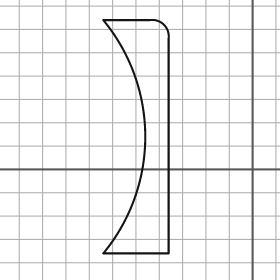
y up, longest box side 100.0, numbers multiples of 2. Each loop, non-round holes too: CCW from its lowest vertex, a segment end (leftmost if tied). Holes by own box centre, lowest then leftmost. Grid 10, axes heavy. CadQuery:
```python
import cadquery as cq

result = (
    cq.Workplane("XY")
    .moveTo(-64.0, -36.0)
    .lineTo(-36.0, -36.0)
    .lineTo(-36.0, 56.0)
    .threePointArc((-38.0, 62.0), (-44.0, 64.0))
    .lineTo(-64.0, 64.0)
    .threePointArc((-46.0, 14.0), (-64.0, -36.0))
    .close()
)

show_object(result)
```